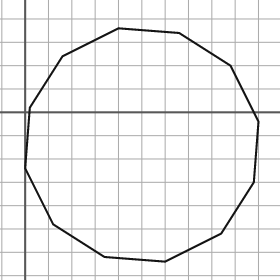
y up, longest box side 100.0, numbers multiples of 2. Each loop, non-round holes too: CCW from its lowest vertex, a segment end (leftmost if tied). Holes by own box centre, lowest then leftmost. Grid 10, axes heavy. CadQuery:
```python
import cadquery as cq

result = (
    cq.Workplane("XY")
    .moveTo(60.0, -64.0)
    .lineTo(84.0, -52.0)
    .lineTo(98.0, -30.0)
    .lineTo(100.0, -4.0)
    .lineTo(88.0, 20.0)
    .lineTo(66.0, 34.0)
    .lineTo(40.0, 36.0)
    .lineTo(16.0, 24.0)
    .lineTo(2.0, 2.0)
    .lineTo(0.0, -24.0)
    .lineTo(12.0, -48.0)
    .lineTo(34.0, -62.0)
    .close()
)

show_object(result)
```